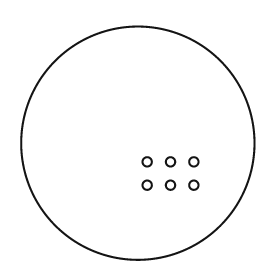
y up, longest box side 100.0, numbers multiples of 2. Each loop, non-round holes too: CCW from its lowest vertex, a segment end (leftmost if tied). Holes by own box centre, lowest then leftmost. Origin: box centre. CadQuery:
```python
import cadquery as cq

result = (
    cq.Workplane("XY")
    .moveTo(0.0, 0.0)
    .circle(50.0)
    .moveTo(4.0, -18.0)
    .circle(2.0)
    .moveTo(14.0, -18.0)
    .circle(2.0)
    .moveTo(24.0, -18.0)
    .circle(2.0)
    .moveTo(4.0, -8.0)
    .circle(2.0)
    .moveTo(14.0, -8.0)
    .circle(2.0)
    .moveTo(24.0, -8.0)
    .circle(2.0)
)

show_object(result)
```